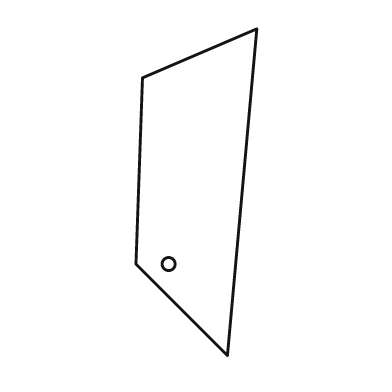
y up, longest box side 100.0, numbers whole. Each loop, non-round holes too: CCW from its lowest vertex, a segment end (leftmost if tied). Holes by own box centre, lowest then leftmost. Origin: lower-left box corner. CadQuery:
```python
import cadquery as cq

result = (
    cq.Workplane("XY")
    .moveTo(28.0, 0.0)
    .lineTo(37.0, 100.0)
    .lineTo(2.0, 85.0)
    .lineTo(0.0, 28.0)
    .close()
    .moveTo(10.0, 28.0)
    .circle(2.0)
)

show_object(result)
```